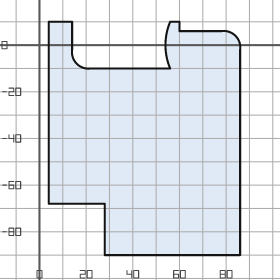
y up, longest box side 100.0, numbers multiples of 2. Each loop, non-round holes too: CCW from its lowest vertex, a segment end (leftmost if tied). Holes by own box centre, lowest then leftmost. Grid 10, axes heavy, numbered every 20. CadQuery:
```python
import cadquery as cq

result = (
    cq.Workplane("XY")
    .moveTo(28.0, -90.0)
    .lineTo(86.0, -90.0)
    .lineTo(86.0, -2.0)
    .threePointArc((84.0, 4.0), (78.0, 6.0))
    .lineTo(60.0, 6.0)
    .lineTo(60.0, 10.0)
    .lineTo(56.0, 10.0)
    .threePointArc((54.0, 0.0), (56.0, -10.0))
    .lineTo(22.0, -10.0)
    .threePointArc((16.0, -8.0), (14.0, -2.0))
    .lineTo(14.0, 10.0)
    .lineTo(4.0, 10.0)
    .lineTo(4.0, -68.0)
    .lineTo(28.0, -68.0)
    .close()
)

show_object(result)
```